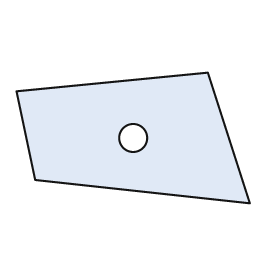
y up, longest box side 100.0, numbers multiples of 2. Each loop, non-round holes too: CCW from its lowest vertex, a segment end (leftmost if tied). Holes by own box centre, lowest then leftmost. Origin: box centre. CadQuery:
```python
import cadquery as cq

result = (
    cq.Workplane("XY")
    .moveTo(50.0, -28.0)
    .lineTo(32.0, 28.0)
    .lineTo(-50.0, 20.0)
    .lineTo(-42.0, -18.0)
    .close()
    .moveTo(0.0, 0.0)
    .circle(6.0)
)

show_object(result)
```